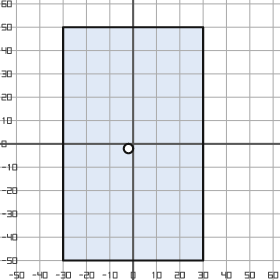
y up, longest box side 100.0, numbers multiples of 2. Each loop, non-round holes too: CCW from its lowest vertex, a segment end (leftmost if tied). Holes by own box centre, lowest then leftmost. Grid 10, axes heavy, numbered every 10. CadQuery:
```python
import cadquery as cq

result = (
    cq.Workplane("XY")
    .moveTo(-30.0, -50.0)
    .lineTo(30.0, -50.0)
    .lineTo(30.0, 50.0)
    .lineTo(-30.0, 50.0)
    .close()
    .moveTo(-2.0, -2.0)
    .circle(2.0)
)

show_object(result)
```